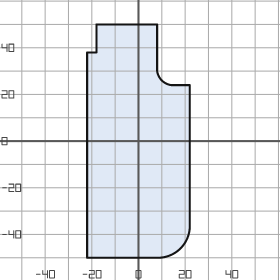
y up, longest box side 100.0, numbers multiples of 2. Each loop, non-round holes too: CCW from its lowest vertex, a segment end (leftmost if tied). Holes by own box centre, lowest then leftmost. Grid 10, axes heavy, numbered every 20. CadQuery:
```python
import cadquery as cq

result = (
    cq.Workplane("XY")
    .moveTo(-22.0, -50.0)
    .lineTo(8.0, -50.0)
    .threePointArc((18.0, -46.0), (22.0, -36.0))
    .lineTo(22.0, 24.0)
    .lineTo(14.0, 24.0)
    .threePointArc((10.0, 26.0), (8.0, 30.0))
    .lineTo(8.0, 50.0)
    .lineTo(-18.0, 50.0)
    .lineTo(-18.0, 38.0)
    .lineTo(-22.0, 38.0)
    .close()
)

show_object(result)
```